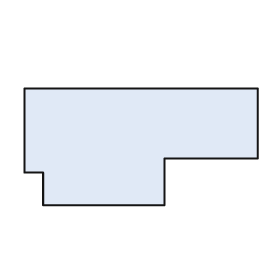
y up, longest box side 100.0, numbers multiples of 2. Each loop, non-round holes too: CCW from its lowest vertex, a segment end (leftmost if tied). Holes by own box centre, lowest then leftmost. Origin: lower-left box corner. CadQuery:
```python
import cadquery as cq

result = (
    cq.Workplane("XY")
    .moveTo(8.0, 0.0)
    .lineTo(60.0, 0.0)
    .lineTo(60.0, 20.0)
    .lineTo(100.0, 20.0)
    .lineTo(100.0, 50.0)
    .lineTo(0.0, 50.0)
    .lineTo(0.0, 14.0)
    .lineTo(8.0, 14.0)
    .close()
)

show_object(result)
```